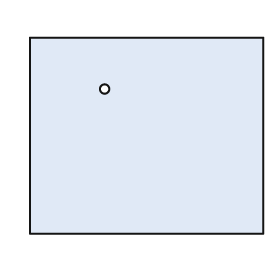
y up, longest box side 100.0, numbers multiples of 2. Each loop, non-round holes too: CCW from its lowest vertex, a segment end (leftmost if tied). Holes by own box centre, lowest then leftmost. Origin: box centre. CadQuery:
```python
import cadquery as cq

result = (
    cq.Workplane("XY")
    .moveTo(-50.0, -42.0)
    .lineTo(50.0, -42.0)
    .lineTo(50.0, 42.0)
    .lineTo(-50.0, 42.0)
    .close()
    .moveTo(-18.0, 20.0)
    .circle(2.0)
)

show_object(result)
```